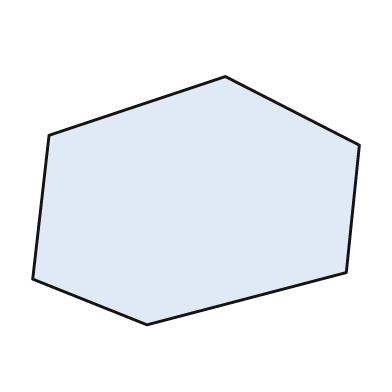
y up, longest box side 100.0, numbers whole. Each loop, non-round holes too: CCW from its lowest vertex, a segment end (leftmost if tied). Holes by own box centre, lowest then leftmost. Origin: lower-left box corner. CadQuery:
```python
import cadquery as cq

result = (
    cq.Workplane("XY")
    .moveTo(35.0, 0.0)
    .lineTo(96.0, 16.0)
    .lineTo(100.0, 55.0)
    .lineTo(59.0, 76.0)
    .lineTo(5.0, 58.0)
    .lineTo(0.0, 14.0)
    .close()
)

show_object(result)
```